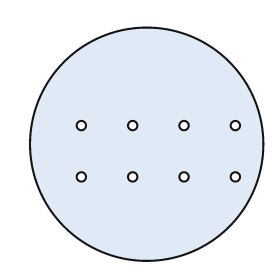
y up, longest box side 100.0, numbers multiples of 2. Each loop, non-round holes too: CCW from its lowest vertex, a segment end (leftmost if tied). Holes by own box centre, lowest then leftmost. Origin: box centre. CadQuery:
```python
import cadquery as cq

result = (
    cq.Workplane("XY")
    .moveTo(0.0, 0.0)
    .circle(50.0)
    .moveTo(-28.0, -14.0)
    .circle(2.0)
    .moveTo(-6.0, -14.0)
    .circle(2.0)
    .moveTo(16.0, -14.0)
    .circle(2.0)
    .moveTo(38.0, -14.0)
    .circle(2.0)
    .moveTo(-28.0, 8.0)
    .circle(2.0)
    .moveTo(-6.0, 8.0)
    .circle(2.0)
    .moveTo(16.0, 8.0)
    .circle(2.0)
    .moveTo(38.0, 8.0)
    .circle(2.0)
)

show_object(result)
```